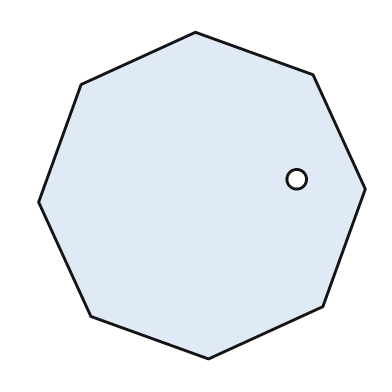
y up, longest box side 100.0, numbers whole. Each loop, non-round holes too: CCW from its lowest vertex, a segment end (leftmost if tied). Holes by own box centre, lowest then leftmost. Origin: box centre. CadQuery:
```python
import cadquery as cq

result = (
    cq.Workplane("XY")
    .moveTo(2.0, -50.0)
    .lineTo(37.0, -34.0)
    .lineTo(50.0, 2.0)
    .lineTo(34.0, 37.0)
    .lineTo(-2.0, 50.0)
    .lineTo(-37.0, 34.0)
    .lineTo(-50.0, -2.0)
    .lineTo(-34.0, -37.0)
    .close()
    .moveTo(29.0, 5.0)
    .circle(3.0)
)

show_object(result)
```